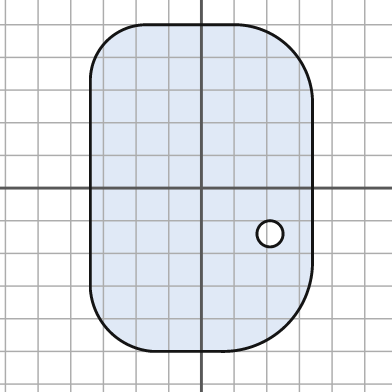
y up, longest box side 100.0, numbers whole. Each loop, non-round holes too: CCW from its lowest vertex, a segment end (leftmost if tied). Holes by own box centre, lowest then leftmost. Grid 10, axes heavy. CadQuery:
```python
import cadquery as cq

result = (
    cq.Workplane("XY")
    .moveTo(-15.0, -50.0)
    .lineTo(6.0, -50.0)
    .threePointArc((26.0, -42.0), (34.0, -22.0))
    .lineTo(34.0, 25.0)
    .threePointArc((27.0, 43.0), (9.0, 50.0))
    .lineTo(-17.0, 50.0)
    .threePointArc((-29.0, 45.0), (-34.0, 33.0))
    .lineTo(-34.0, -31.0)
    .threePointArc((-28.0, -44.0), (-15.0, -50.0))
    .close()
    .moveTo(21.0, -14.0)
    .circle(4.0)
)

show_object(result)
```